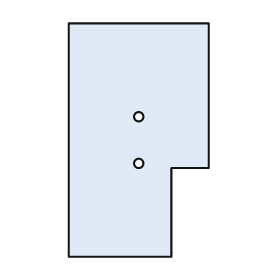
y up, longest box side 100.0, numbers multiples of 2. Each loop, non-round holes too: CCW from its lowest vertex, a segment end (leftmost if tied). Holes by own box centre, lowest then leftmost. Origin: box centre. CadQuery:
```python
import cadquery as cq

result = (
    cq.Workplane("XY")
    .moveTo(-30.0, -50.0)
    .lineTo(14.0, -50.0)
    .lineTo(14.0, -12.0)
    .lineTo(30.0, -12.0)
    .lineTo(30.0, 50.0)
    .lineTo(-30.0, 50.0)
    .close()
    .moveTo(0.0, -10.0)
    .circle(2.0)
    .moveTo(0.0, 10.0)
    .circle(2.0)
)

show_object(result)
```